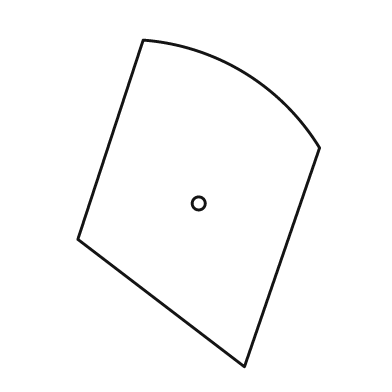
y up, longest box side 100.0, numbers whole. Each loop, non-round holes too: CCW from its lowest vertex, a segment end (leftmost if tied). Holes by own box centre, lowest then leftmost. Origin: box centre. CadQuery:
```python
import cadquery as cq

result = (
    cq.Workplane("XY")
    .moveTo(14.0, -50.0)
    .lineTo(37.0, 17.0)
    .threePointArc((14.0, 40.0), (-17.0, 50.0))
    .lineTo(-37.0, -11.0)
    .close()
    .moveTo(0.0, 0.0)
    .circle(2.0)
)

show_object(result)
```